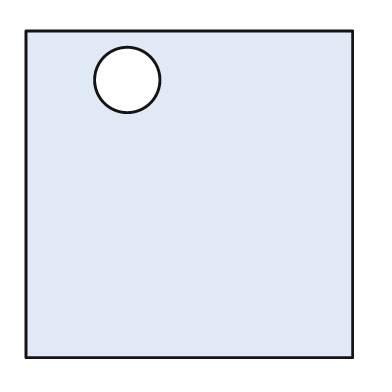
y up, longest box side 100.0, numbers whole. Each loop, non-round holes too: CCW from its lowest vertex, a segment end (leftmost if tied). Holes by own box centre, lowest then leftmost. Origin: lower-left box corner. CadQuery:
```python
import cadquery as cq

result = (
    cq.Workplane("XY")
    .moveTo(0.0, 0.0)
    .lineTo(100.0, 0.0)
    .lineTo(100.0, 100.0)
    .lineTo(0.0, 100.0)
    .close()
    .moveTo(31.0, 85.0)
    .circle(10.0)
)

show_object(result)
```